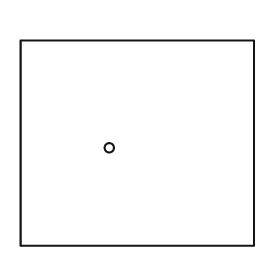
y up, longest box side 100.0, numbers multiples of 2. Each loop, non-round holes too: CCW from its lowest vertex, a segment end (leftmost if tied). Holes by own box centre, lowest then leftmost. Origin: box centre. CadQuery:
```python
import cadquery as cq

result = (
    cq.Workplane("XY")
    .moveTo(-50.0, -44.0)
    .lineTo(50.0, -44.0)
    .lineTo(50.0, 44.0)
    .lineTo(-50.0, 44.0)
    .close()
    .moveTo(-12.0, -2.0)
    .circle(2.0)
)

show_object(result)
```